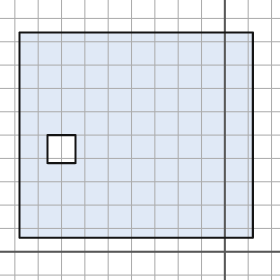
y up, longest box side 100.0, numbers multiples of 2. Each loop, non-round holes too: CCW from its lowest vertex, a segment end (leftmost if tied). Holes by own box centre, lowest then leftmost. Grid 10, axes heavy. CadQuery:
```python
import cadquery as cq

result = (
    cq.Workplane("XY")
    .moveTo(-88.0, 6.0)
    .lineTo(12.0, 6.0)
    .lineTo(12.0, 94.0)
    .lineTo(-88.0, 94.0)
    .close()
    .moveTo(-76.0, 38.0)
    .lineTo(-64.0, 38.0)
    .lineTo(-64.0, 50.0)
    .lineTo(-76.0, 50.0)
    .close()
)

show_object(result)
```